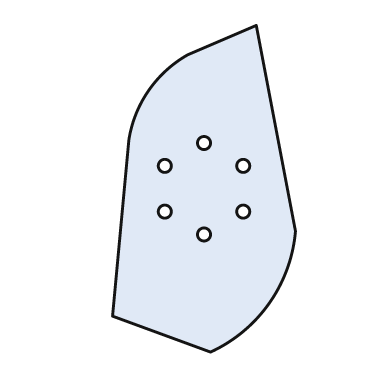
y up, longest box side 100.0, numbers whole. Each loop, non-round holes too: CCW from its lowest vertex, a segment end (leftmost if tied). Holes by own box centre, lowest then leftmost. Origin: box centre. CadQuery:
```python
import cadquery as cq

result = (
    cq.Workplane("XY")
    .moveTo(2.0, -50.0)
    .threePointArc((20.0, -35.0), (28.0, -13.0))
    .lineTo(16.0, 50.0)
    .lineTo(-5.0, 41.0)
    .threePointArc((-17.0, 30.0), (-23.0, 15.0))
    .lineTo(-28.0, -39.0)
    .close()
    .moveTo(0.0, -14.0)
    .circle(2.0)
    .moveTo(-12.0, -7.0)
    .circle(2.0)
    .moveTo(12.0, -7.0)
    .circle(2.0)
    .moveTo(-12.0, 7.0)
    .circle(2.0)
    .moveTo(12.0, 7.0)
    .circle(2.0)
    .moveTo(0.0, 14.0)
    .circle(2.0)
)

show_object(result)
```